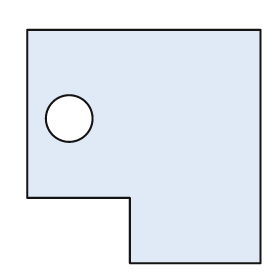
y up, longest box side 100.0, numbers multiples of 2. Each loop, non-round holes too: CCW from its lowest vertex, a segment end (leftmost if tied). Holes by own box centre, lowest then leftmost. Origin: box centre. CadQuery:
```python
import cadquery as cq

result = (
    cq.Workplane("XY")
    .moveTo(-6.0, -50.0)
    .lineTo(50.0, -50.0)
    .lineTo(50.0, 50.0)
    .lineTo(-50.0, 50.0)
    .lineTo(-50.0, -22.0)
    .lineTo(-6.0, -22.0)
    .close()
    .moveTo(-32.0, 12.0)
    .circle(10.0)
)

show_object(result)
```